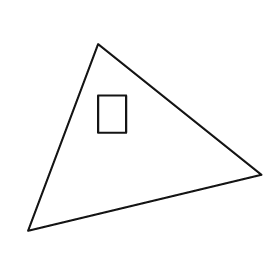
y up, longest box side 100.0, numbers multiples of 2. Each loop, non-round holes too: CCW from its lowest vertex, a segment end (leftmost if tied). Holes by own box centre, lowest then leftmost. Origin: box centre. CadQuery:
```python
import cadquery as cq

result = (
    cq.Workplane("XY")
    .moveTo(-50.0, -40.0)
    .lineTo(50.0, -16.0)
    .lineTo(-20.0, 40.0)
    .close()
    .moveTo(-20.0, 2.0)
    .lineTo(-8.0, 2.0)
    .lineTo(-8.0, 18.0)
    .lineTo(-20.0, 18.0)
    .close()
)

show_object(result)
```